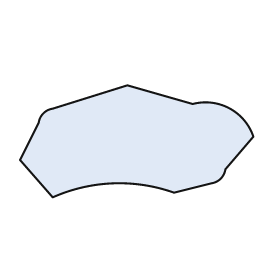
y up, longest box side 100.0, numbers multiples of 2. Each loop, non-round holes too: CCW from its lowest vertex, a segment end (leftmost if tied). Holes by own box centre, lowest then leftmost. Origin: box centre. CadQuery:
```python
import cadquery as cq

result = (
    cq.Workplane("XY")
    .moveTo(-36.0, -24.0)
    .threePointArc((-10.0, -18.0), (16.0, -22.0))
    .lineTo(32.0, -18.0)
    .threePointArc((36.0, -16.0), (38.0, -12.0))
    .lineTo(50.0, 2.0)
    .threePointArc((40.0, 14.0), (24.0, 16.0))
    .lineTo(-4.0, 24.0)
    .lineTo(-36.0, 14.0)
    .threePointArc((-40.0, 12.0), (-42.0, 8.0))
    .lineTo(-50.0, -8.0)
    .close()
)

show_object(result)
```